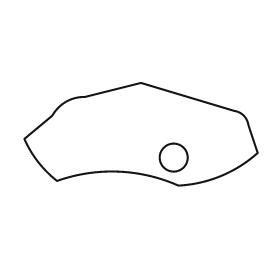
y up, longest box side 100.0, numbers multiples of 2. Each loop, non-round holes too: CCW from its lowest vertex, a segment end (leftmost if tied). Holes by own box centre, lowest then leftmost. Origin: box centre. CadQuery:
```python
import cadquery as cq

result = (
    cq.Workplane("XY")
    .moveTo(16.0, -22.0)
    .threePointArc((34.0, -18.0), (50.0, -8.0))
    .lineTo(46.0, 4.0)
    .threePointArc((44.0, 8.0), (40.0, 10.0))
    .lineTo(0.0, 22.0)
    .lineTo(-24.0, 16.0)
    .threePointArc((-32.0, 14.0), (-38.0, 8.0))
    .lineTo(-50.0, -2.0)
    .threePointArc((-44.0, -12.0), (-36.0, -20.0))
    .threePointArc((-10.0, -16.0), (16.0, -22.0))
    .close()
    .moveTo(14.0, -10.0)
    .circle(6.0)
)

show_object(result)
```